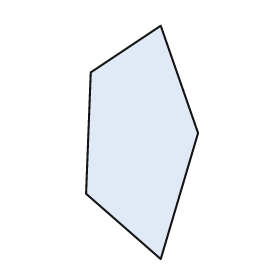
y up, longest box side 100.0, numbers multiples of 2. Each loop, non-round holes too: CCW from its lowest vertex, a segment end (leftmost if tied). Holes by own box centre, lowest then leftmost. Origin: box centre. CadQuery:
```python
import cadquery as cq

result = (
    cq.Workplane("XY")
    .moveTo(8.0, -50.0)
    .lineTo(24.0, 4.0)
    .lineTo(8.0, 50.0)
    .lineTo(-22.0, 30.0)
    .lineTo(-24.0, -22.0)
    .close()
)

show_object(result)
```